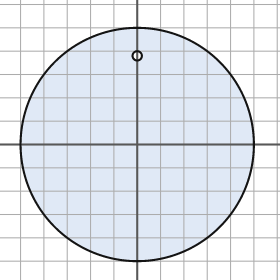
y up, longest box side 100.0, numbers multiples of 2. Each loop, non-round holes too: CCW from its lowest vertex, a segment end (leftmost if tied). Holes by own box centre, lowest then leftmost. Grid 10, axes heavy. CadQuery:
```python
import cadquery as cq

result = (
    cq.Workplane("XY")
    .moveTo(0.0, 0.0)
    .circle(50.0)
    .moveTo(0.0, 38.0)
    .circle(2.0)
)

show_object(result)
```